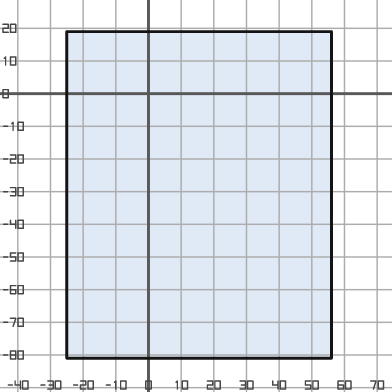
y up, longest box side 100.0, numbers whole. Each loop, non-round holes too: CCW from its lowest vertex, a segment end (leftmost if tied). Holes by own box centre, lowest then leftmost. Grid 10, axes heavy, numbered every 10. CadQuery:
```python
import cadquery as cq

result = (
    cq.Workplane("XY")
    .moveTo(-25.0, -81.0)
    .lineTo(56.0, -81.0)
    .lineTo(56.0, 19.0)
    .lineTo(-25.0, 19.0)
    .close()
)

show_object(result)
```